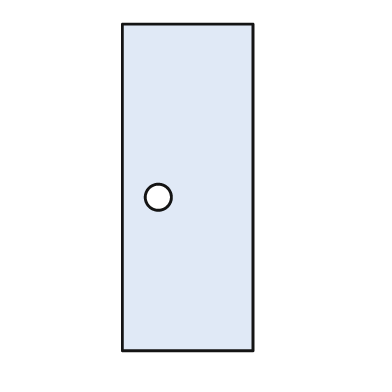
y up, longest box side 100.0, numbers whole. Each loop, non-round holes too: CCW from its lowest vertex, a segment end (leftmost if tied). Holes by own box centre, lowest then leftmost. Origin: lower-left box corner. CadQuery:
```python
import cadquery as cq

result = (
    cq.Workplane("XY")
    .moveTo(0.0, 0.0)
    .lineTo(40.0, 0.0)
    .lineTo(40.0, 100.0)
    .lineTo(0.0, 100.0)
    .close()
    .moveTo(11.0, 47.0)
    .circle(4.0)
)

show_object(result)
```